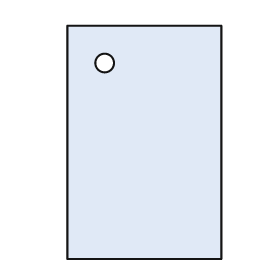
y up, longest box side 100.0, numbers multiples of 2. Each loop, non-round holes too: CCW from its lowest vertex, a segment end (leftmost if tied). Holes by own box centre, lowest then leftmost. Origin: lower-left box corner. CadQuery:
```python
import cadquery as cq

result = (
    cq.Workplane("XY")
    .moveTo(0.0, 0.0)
    .lineTo(66.0, 0.0)
    .lineTo(66.0, 100.0)
    .lineTo(0.0, 100.0)
    .close()
    .moveTo(16.0, 84.0)
    .circle(4.0)
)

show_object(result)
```